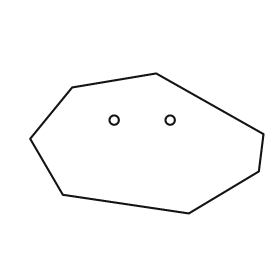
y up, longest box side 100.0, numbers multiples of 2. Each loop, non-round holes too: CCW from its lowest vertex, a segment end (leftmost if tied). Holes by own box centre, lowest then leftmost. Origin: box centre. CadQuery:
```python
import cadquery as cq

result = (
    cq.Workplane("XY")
    .moveTo(18.0, -30.0)
    .lineTo(48.0, -12.0)
    .lineTo(50.0, 4.0)
    .lineTo(4.0, 30.0)
    .lineTo(-32.0, 24.0)
    .lineTo(-50.0, 2.0)
    .lineTo(-36.0, -22.0)
    .close()
    .moveTo(-14.0, 10.0)
    .circle(2.0)
    .moveTo(10.0, 10.0)
    .circle(2.0)
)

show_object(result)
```